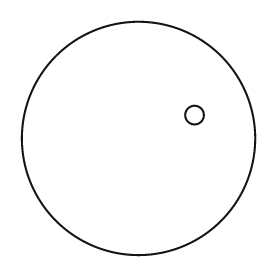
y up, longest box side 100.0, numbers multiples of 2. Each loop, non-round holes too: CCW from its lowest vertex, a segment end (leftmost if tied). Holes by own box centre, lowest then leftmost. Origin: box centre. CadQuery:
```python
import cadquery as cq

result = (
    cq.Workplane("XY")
    .moveTo(0.0, 0.0)
    .circle(50.0)
    .moveTo(24.0, 10.0)
    .circle(4.0)
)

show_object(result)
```